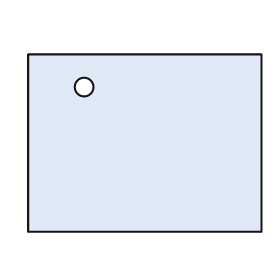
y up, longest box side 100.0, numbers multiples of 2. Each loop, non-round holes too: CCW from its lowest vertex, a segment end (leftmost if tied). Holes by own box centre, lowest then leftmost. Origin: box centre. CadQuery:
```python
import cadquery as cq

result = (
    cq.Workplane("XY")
    .moveTo(-50.0, -38.0)
    .lineTo(50.0, -38.0)
    .lineTo(50.0, 38.0)
    .lineTo(-50.0, 38.0)
    .close()
    .moveTo(-26.0, 24.0)
    .circle(4.0)
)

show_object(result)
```